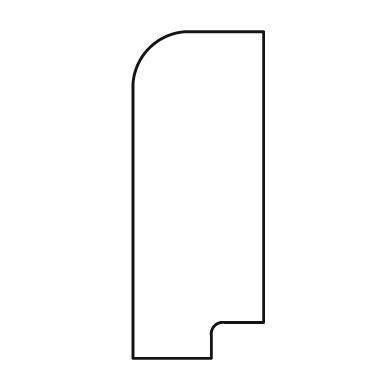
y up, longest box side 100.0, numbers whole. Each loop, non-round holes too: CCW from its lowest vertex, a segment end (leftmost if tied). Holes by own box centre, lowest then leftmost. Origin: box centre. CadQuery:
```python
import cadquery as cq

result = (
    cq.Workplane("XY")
    .moveTo(-20.0, -50.0)
    .lineTo(4.0, -50.0)
    .lineTo(4.0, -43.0)
    .threePointArc((5.0, -40.0), (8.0, -39.0))
    .lineTo(20.0, -39.0)
    .lineTo(20.0, 50.0)
    .lineTo(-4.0, 50.0)
    .threePointArc((-15.0, 45.0), (-20.0, 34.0))
    .close()
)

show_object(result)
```